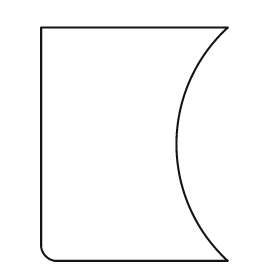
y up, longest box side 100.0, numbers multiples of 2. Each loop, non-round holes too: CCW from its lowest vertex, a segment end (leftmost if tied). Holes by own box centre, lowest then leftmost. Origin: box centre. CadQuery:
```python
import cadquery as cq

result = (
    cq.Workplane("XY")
    .moveTo(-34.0, -50.0)
    .lineTo(40.0, -50.0)
    .threePointArc((18.0, 0.0), (40.0, 50.0))
    .lineTo(-40.0, 50.0)
    .lineTo(-40.0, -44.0)
    .threePointArc((-38.0, -48.0), (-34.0, -50.0))
    .close()
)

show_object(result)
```